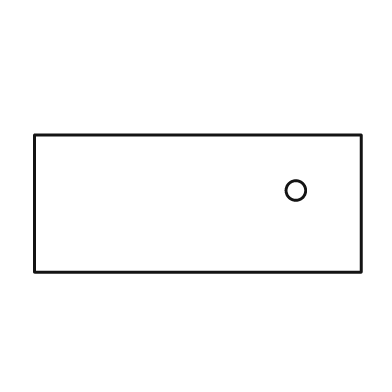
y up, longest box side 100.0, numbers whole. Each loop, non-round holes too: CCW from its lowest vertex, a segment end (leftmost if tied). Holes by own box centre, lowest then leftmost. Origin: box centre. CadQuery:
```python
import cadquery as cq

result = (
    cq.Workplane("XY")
    .moveTo(-50.0, -21.0)
    .lineTo(50.0, -21.0)
    .lineTo(50.0, 21.0)
    .lineTo(-50.0, 21.0)
    .close()
    .moveTo(30.0, 4.0)
    .circle(3.0)
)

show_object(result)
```